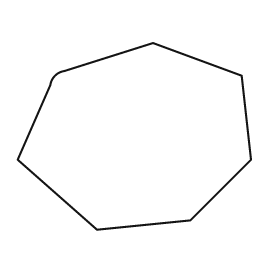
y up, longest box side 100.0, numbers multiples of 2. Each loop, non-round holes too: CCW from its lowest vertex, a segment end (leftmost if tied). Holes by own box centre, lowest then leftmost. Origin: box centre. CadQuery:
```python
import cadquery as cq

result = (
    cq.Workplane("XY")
    .moveTo(-16.0, -40.0)
    .lineTo(24.0, -36.0)
    .lineTo(50.0, -10.0)
    .lineTo(46.0, 26.0)
    .lineTo(8.0, 40.0)
    .lineTo(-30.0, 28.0)
    .threePointArc((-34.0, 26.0), (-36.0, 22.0))
    .lineTo(-50.0, -10.0)
    .close()
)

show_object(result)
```